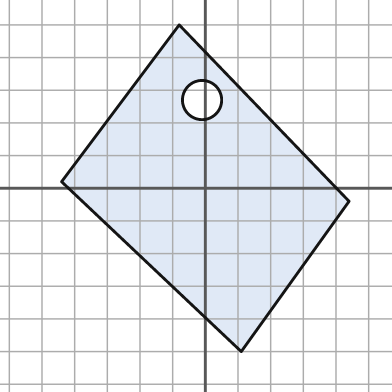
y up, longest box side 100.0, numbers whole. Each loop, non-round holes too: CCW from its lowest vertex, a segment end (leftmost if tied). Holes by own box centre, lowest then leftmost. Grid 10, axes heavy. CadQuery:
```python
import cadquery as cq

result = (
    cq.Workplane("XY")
    .moveTo(11.0, -50.0)
    .lineTo(44.0, -4.0)
    .lineTo(-8.0, 50.0)
    .lineTo(-44.0, 2.0)
    .close()
    .moveTo(-1.0, 27.0)
    .circle(6.0)
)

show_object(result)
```